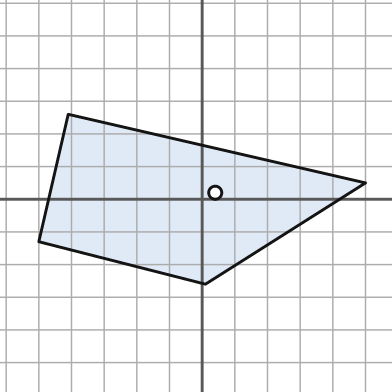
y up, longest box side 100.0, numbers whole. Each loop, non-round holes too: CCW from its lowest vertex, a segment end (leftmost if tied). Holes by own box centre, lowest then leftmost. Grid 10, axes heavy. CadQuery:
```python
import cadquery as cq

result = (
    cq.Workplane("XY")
    .moveTo(1.0, -26.0)
    .lineTo(50.0, 5.0)
    .lineTo(-41.0, 26.0)
    .lineTo(-50.0, -13.0)
    .close()
    .moveTo(4.0, 2.0)
    .circle(2.0)
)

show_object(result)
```